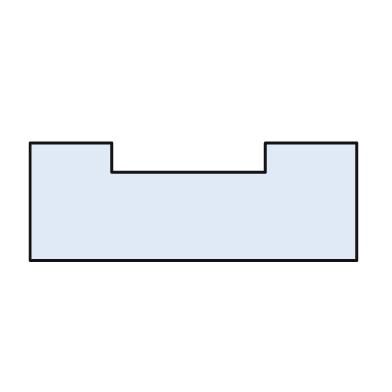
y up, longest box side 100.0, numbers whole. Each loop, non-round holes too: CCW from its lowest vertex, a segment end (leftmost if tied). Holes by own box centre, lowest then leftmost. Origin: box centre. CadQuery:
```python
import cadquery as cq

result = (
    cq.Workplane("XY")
    .moveTo(-50.0, -18.0)
    .lineTo(50.0, -18.0)
    .lineTo(50.0, 18.0)
    .lineTo(22.0, 18.0)
    .lineTo(22.0, 9.0)
    .lineTo(-25.0, 9.0)
    .lineTo(-25.0, 18.0)
    .lineTo(-50.0, 18.0)
    .close()
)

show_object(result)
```